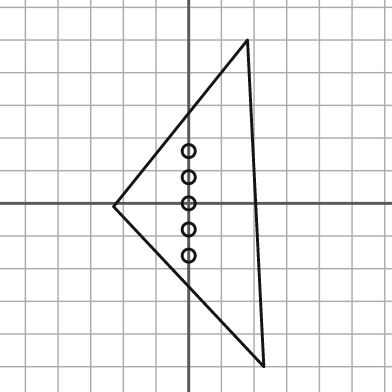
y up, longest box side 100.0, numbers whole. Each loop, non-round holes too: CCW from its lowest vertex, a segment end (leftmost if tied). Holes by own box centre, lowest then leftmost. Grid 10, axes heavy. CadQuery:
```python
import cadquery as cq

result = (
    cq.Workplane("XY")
    .moveTo(23.0, -50.0)
    .lineTo(18.0, 50.0)
    .lineTo(-23.0, -1.0)
    .close()
    .moveTo(0.0, -16.0)
    .circle(2.0)
    .moveTo(0.0, -8.0)
    .circle(2.0)
    .moveTo(0.0, 0.0)
    .circle(2.0)
    .moveTo(0.0, 8.0)
    .circle(2.0)
    .moveTo(0.0, 16.0)
    .circle(2.0)
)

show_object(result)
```